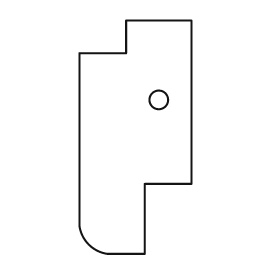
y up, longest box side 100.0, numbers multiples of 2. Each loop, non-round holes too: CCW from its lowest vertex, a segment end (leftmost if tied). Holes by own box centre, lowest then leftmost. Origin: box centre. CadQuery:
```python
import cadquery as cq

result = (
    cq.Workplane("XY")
    .moveTo(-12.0, -50.0)
    .lineTo(4.0, -50.0)
    .lineTo(4.0, -20.0)
    .lineTo(24.0, -20.0)
    .lineTo(24.0, 50.0)
    .lineTo(-4.0, 50.0)
    .lineTo(-4.0, 36.0)
    .lineTo(-24.0, 36.0)
    .lineTo(-24.0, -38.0)
    .threePointArc((-20.0, -46.0), (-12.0, -50.0))
    .close()
    .moveTo(10.0, 16.0)
    .circle(4.0)
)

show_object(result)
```